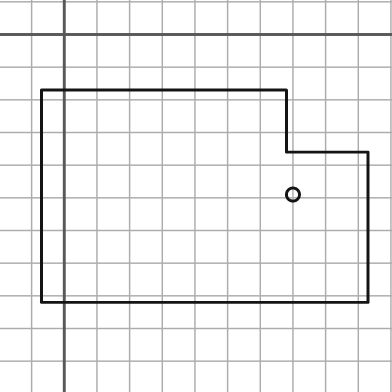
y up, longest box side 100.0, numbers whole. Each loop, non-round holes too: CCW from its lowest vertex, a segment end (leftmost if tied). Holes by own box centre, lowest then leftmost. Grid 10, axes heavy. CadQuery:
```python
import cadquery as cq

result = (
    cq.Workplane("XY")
    .moveTo(-7.0, -82.0)
    .lineTo(93.0, -82.0)
    .lineTo(93.0, -36.0)
    .lineTo(68.0, -36.0)
    .lineTo(68.0, -17.0)
    .lineTo(-7.0, -17.0)
    .close()
    .moveTo(70.0, -49.0)
    .circle(2.0)
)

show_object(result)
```